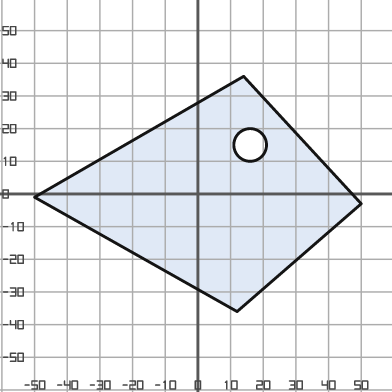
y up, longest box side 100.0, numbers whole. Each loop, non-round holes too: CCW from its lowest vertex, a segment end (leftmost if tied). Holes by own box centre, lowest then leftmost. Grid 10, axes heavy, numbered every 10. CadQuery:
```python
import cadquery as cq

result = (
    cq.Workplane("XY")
    .moveTo(12.0, -36.0)
    .lineTo(50.0, -3.0)
    .lineTo(14.0, 36.0)
    .lineTo(-50.0, -1.0)
    .close()
    .moveTo(16.0, 15.0)
    .circle(5.0)
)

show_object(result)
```